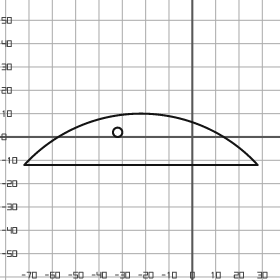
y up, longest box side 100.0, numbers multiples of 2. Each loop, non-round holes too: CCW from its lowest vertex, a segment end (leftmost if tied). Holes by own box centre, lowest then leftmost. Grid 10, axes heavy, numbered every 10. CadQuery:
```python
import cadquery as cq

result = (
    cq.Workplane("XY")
    .moveTo(-72.0, -12.0)
    .lineTo(28.0, -12.0)
    .threePointArc((-22.0, 10.0), (-72.0, -12.0))
    .close()
    .moveTo(-32.0, 2.0)
    .circle(2.0)
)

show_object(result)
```